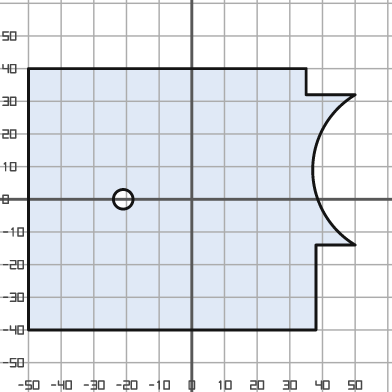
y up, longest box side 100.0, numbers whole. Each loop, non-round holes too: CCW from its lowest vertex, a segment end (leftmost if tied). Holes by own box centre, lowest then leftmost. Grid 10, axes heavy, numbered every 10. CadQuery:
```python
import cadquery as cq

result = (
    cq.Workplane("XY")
    .moveTo(-50.0, -40.0)
    .lineTo(38.0, -40.0)
    .lineTo(38.0, -14.0)
    .lineTo(50.0, -14.0)
    .threePointArc((37.0, 9.0), (50.0, 32.0))
    .lineTo(35.0, 32.0)
    .lineTo(35.0, 40.0)
    .lineTo(-50.0, 40.0)
    .close()
    .moveTo(-21.0, 0.0)
    .circle(3.0)
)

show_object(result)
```